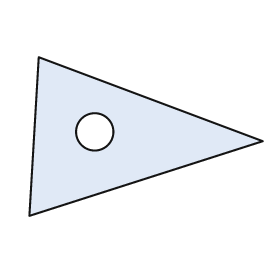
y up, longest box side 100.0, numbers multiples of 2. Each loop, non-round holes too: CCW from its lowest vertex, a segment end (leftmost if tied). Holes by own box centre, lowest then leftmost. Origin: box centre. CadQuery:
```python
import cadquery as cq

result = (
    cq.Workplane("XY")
    .moveTo(-50.0, -34.0)
    .lineTo(50.0, -2.0)
    .lineTo(-46.0, 34.0)
    .close()
    .moveTo(-22.0, 2.0)
    .circle(8.0)
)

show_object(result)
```